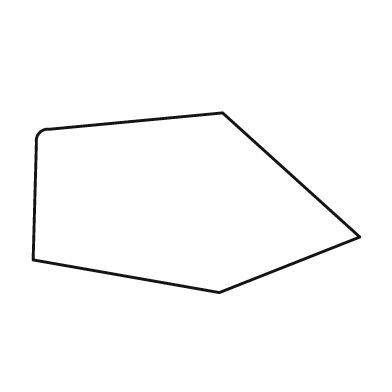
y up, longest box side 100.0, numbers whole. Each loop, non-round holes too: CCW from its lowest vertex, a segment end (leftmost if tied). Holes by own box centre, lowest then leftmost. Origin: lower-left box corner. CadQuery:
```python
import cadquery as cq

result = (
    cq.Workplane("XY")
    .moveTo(57.0, 0.0)
    .lineTo(100.0, 17.0)
    .lineTo(58.0, 55.0)
    .lineTo(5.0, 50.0)
    .threePointArc((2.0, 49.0), (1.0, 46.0))
    .lineTo(0.0, 10.0)
    .close()
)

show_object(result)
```